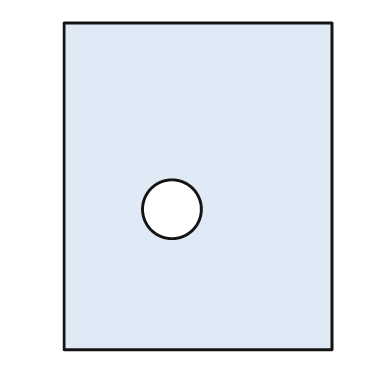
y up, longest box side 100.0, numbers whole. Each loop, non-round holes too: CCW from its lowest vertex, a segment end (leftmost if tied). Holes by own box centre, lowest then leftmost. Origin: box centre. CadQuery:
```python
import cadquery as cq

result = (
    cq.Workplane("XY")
    .moveTo(-41.0, -50.0)
    .lineTo(41.0, -50.0)
    .lineTo(41.0, 50.0)
    .lineTo(-41.0, 50.0)
    .close()
    .moveTo(-8.0, -7.0)
    .circle(9.0)
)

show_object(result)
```